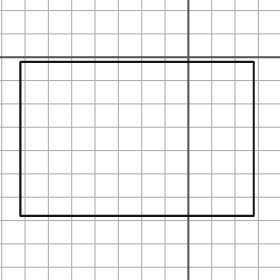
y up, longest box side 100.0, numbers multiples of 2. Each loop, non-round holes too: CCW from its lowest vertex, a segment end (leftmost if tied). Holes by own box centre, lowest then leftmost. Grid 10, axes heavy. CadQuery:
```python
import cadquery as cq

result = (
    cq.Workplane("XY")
    .moveTo(-72.0, -68.0)
    .lineTo(28.0, -68.0)
    .lineTo(28.0, -2.0)
    .lineTo(-72.0, -2.0)
    .close()
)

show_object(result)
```